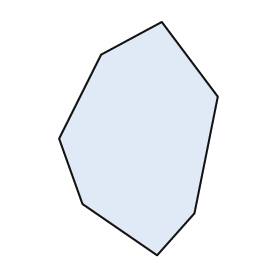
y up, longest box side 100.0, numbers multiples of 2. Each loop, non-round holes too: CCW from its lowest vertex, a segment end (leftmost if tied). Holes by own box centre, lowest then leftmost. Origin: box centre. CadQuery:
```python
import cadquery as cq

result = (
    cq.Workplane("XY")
    .moveTo(8.0, -50.0)
    .lineTo(24.0, -32.0)
    .lineTo(34.0, 18.0)
    .lineTo(10.0, 50.0)
    .lineTo(-16.0, 36.0)
    .lineTo(-34.0, 0.0)
    .lineTo(-24.0, -28.0)
    .close()
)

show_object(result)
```